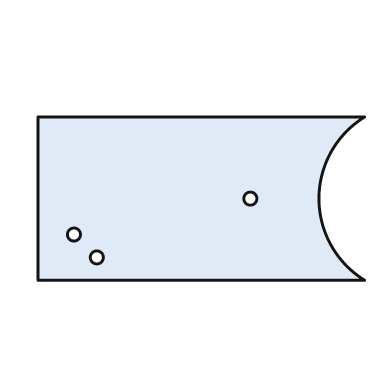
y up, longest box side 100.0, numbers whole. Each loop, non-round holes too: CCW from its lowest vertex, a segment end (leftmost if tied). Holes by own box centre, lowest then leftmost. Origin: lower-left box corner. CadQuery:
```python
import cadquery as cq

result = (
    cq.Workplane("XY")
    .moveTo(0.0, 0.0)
    .lineTo(100.0, 0.0)
    .threePointArc((86.0, 25.0), (100.0, 50.0))
    .lineTo(0.0, 50.0)
    .close()
    .moveTo(18.0, 7.0)
    .circle(2.0)
    .moveTo(11.0, 14.0)
    .circle(2.0)
    .moveTo(65.0, 25.0)
    .circle(2.0)
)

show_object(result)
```